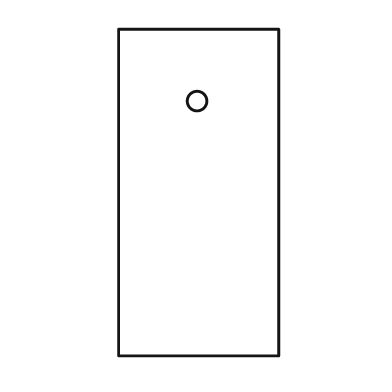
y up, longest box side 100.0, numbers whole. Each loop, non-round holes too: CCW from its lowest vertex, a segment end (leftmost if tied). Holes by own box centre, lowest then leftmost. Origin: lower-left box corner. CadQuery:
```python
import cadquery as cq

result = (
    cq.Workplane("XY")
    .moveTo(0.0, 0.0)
    .lineTo(49.0, 0.0)
    .lineTo(49.0, 100.0)
    .lineTo(0.0, 100.0)
    .close()
    .moveTo(24.0, 78.0)
    .circle(3.0)
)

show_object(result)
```